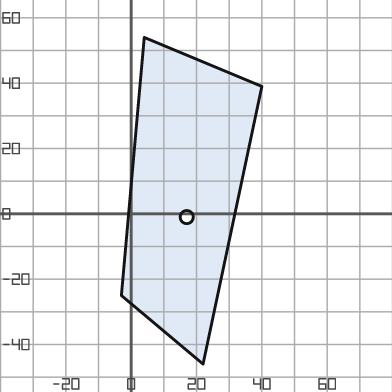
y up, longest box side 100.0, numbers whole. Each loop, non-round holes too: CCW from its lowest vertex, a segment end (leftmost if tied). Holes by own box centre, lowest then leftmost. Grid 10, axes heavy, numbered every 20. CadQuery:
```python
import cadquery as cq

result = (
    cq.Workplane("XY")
    .moveTo(22.0, -46.0)
    .lineTo(40.0, 39.0)
    .lineTo(4.0, 54.0)
    .lineTo(-3.0, -25.0)
    .close()
    .moveTo(17.0, -1.0)
    .circle(2.0)
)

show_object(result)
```